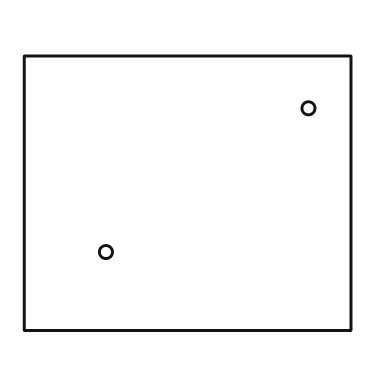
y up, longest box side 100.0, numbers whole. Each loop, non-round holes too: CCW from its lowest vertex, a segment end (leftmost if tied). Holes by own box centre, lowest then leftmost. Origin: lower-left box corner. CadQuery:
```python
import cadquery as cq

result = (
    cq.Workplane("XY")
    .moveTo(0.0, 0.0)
    .lineTo(100.0, 0.0)
    .lineTo(100.0, 84.0)
    .lineTo(0.0, 84.0)
    .close()
    .moveTo(25.0, 24.0)
    .circle(2.0)
    .moveTo(87.0, 68.0)
    .circle(2.0)
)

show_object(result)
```